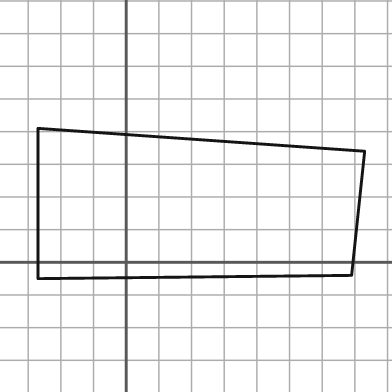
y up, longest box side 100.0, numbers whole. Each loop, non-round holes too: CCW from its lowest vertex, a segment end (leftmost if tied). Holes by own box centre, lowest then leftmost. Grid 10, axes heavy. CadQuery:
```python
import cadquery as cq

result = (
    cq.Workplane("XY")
    .moveTo(-27.0, -5.0)
    .lineTo(69.0, -4.0)
    .lineTo(73.0, 34.0)
    .lineTo(-27.0, 41.0)
    .close()
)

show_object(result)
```